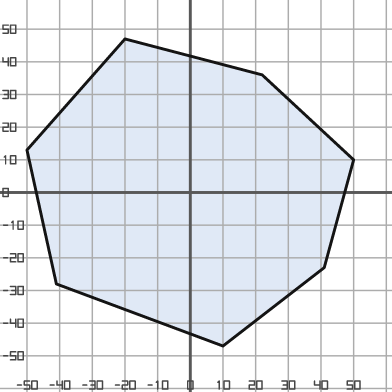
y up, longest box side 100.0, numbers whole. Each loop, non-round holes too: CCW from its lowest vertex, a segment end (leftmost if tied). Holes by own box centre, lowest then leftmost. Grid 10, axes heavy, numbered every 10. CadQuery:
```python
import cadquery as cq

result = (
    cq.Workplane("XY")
    .moveTo(10.0, -47.0)
    .lineTo(41.0, -23.0)
    .lineTo(50.0, 10.0)
    .lineTo(22.0, 36.0)
    .lineTo(-20.0, 47.0)
    .lineTo(-50.0, 13.0)
    .lineTo(-41.0, -28.0)
    .close()
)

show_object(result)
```